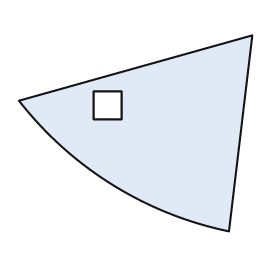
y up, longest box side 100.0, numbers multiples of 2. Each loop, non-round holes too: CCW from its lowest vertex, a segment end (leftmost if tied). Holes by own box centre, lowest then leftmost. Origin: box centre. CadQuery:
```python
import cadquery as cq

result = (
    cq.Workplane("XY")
    .moveTo(40.0, -42.0)
    .lineTo(50.0, 42.0)
    .lineTo(-50.0, 14.0)
    .threePointArc((-10.0, -22.0), (40.0, -42.0))
    .close()
    .moveTo(-18.0, 6.0)
    .lineTo(-6.0, 6.0)
    .lineTo(-6.0, 18.0)
    .lineTo(-18.0, 18.0)
    .close()
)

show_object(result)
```